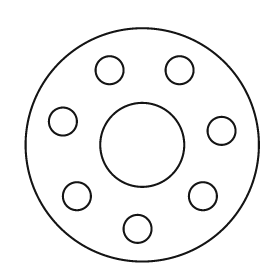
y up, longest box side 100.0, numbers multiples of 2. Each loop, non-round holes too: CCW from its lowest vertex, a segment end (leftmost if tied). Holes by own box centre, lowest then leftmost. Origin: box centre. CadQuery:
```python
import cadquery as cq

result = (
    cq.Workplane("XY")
    .moveTo(0.0, 0.0)
    .circle(50.0)
    .moveTo(-2.0, -36.0)
    .circle(6.0)
    .moveTo(-28.0, -22.0)
    .circle(6.0)
    .moveTo(26.0, -22.0)
    .circle(6.0)
    .moveTo(0.0, 0.0)
    .circle(18.0)
    .moveTo(34.0, 6.0)
    .circle(6.0)
    .moveTo(-34.0, 10.0)
    .circle(6.0)
    .moveTo(-14.0, 32.0)
    .circle(6.0)
    .moveTo(16.0, 32.0)
    .circle(6.0)
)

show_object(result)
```